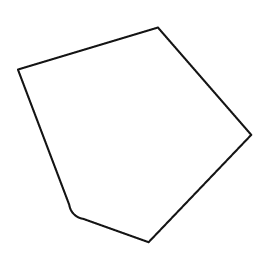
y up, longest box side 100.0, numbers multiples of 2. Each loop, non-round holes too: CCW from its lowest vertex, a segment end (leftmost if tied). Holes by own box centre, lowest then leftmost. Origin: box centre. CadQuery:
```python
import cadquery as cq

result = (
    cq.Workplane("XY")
    .moveTo(6.0, -46.0)
    .lineTo(50.0, 0.0)
    .lineTo(10.0, 46.0)
    .lineTo(-50.0, 28.0)
    .lineTo(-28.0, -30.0)
    .threePointArc((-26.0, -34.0), (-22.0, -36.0))
    .close()
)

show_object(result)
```